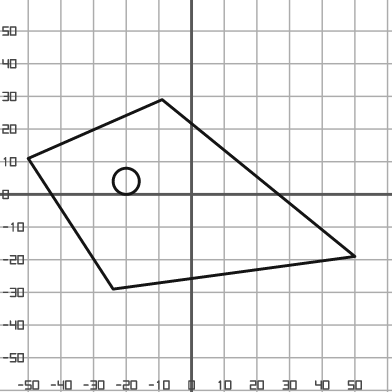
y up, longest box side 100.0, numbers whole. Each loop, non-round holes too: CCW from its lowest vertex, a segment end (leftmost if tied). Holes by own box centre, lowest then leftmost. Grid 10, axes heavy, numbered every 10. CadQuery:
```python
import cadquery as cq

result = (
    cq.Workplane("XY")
    .moveTo(-24.0, -29.0)
    .lineTo(50.0, -19.0)
    .lineTo(-9.0, 29.0)
    .lineTo(-50.0, 11.0)
    .close()
    .moveTo(-20.0, 4.0)
    .circle(4.0)
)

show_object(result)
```